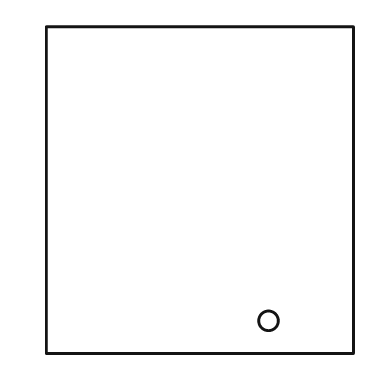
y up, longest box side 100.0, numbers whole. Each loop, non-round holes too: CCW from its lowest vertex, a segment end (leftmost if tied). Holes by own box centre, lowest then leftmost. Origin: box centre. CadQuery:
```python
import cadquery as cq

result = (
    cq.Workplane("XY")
    .moveTo(-47.0, -50.0)
    .lineTo(47.0, -50.0)
    .lineTo(47.0, 50.0)
    .lineTo(-47.0, 50.0)
    .close()
    .moveTo(21.0, -40.0)
    .circle(3.0)
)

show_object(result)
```